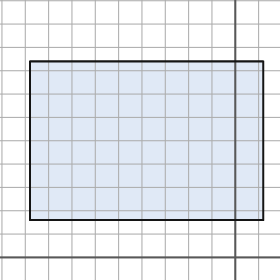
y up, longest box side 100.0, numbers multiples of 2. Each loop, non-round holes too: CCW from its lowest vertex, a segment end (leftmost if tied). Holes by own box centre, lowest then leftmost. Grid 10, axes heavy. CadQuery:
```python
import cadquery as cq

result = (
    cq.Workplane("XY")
    .moveTo(-88.0, 16.0)
    .lineTo(12.0, 16.0)
    .lineTo(12.0, 84.0)
    .lineTo(-88.0, 84.0)
    .close()
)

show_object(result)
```